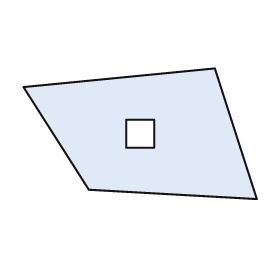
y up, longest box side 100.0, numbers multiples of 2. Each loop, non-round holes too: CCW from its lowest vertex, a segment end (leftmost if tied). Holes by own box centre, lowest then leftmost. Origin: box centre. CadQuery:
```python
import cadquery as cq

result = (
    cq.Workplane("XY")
    .moveTo(50.0, -28.0)
    .lineTo(32.0, 28.0)
    .lineTo(-50.0, 20.0)
    .lineTo(-22.0, -24.0)
    .close()
    .moveTo(-6.0, -6.0)
    .lineTo(6.0, -6.0)
    .lineTo(6.0, 6.0)
    .lineTo(-6.0, 6.0)
    .close()
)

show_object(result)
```